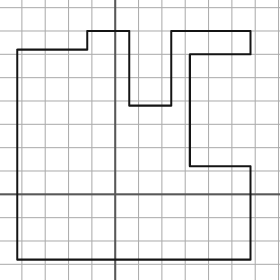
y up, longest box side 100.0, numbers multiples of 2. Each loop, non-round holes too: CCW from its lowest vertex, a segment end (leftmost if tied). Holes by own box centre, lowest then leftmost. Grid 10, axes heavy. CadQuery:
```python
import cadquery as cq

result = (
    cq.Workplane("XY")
    .moveTo(-42.0, -28.0)
    .lineTo(58.0, -28.0)
    .lineTo(58.0, 12.0)
    .lineTo(32.0, 12.0)
    .lineTo(32.0, 60.0)
    .lineTo(58.0, 60.0)
    .lineTo(58.0, 70.0)
    .lineTo(24.0, 70.0)
    .lineTo(24.0, 38.0)
    .lineTo(6.0, 38.0)
    .lineTo(6.0, 70.0)
    .lineTo(-12.0, 70.0)
    .lineTo(-12.0, 62.0)
    .lineTo(-42.0, 62.0)
    .close()
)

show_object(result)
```